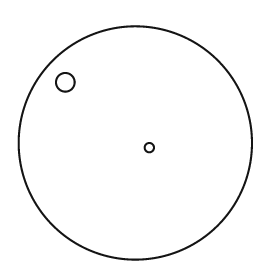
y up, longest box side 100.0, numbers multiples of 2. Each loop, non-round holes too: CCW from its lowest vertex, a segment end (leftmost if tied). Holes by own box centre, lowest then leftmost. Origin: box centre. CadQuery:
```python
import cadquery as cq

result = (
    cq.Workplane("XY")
    .moveTo(0.0, 0.0)
    .circle(50.0)
    .moveTo(6.0, -2.0)
    .circle(2.0)
    .moveTo(-30.0, 26.0)
    .circle(4.0)
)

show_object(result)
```